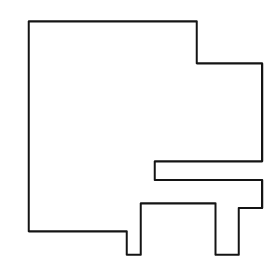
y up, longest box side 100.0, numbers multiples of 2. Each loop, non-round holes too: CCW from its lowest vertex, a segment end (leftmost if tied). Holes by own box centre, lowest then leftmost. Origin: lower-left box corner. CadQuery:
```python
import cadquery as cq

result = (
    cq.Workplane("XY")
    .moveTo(42.0, 0.0)
    .lineTo(48.0, 0.0)
    .lineTo(48.0, 22.0)
    .lineTo(80.0, 22.0)
    .lineTo(80.0, 0.0)
    .lineTo(90.0, 0.0)
    .lineTo(90.0, 20.0)
    .lineTo(100.0, 20.0)
    .lineTo(100.0, 32.0)
    .lineTo(54.0, 32.0)
    .lineTo(54.0, 40.0)
    .lineTo(100.0, 40.0)
    .lineTo(100.0, 82.0)
    .lineTo(72.0, 82.0)
    .lineTo(72.0, 100.0)
    .lineTo(0.0, 100.0)
    .lineTo(0.0, 10.0)
    .lineTo(42.0, 10.0)
    .close()
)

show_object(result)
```